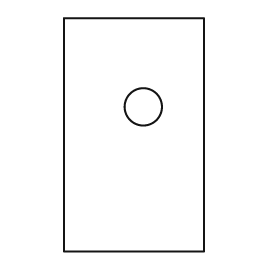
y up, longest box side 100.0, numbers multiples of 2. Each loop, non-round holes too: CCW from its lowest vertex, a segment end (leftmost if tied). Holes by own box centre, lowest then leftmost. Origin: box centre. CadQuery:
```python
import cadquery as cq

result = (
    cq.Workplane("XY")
    .moveTo(-30.0, -50.0)
    .lineTo(30.0, -50.0)
    .lineTo(30.0, 50.0)
    .lineTo(-30.0, 50.0)
    .close()
    .moveTo(4.0, 12.0)
    .circle(8.0)
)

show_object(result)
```